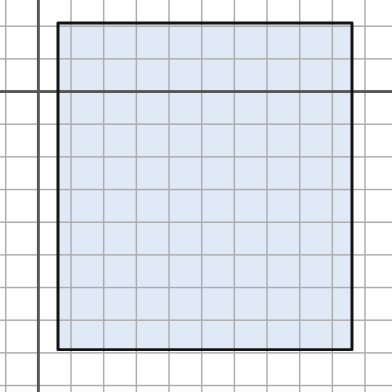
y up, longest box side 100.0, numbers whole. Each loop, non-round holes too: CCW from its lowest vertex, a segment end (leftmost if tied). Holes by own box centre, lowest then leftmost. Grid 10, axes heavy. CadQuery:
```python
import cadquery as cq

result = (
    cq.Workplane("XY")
    .moveTo(6.0, -79.0)
    .lineTo(96.0, -79.0)
    .lineTo(96.0, 21.0)
    .lineTo(6.0, 21.0)
    .close()
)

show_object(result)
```